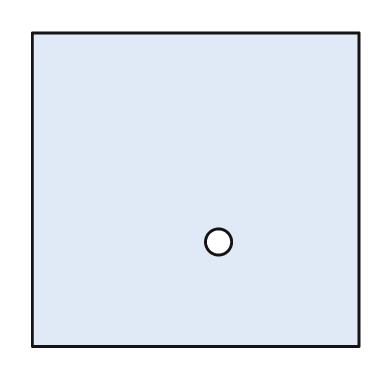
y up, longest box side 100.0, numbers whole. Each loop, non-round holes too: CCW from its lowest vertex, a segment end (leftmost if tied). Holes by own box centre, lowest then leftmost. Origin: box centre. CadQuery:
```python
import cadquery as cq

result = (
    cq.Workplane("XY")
    .moveTo(-50.0, -48.0)
    .lineTo(50.0, -48.0)
    .lineTo(50.0, 48.0)
    .lineTo(-50.0, 48.0)
    .close()
    .moveTo(7.0, -16.0)
    .circle(4.0)
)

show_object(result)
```